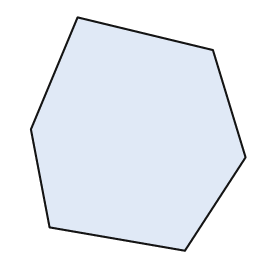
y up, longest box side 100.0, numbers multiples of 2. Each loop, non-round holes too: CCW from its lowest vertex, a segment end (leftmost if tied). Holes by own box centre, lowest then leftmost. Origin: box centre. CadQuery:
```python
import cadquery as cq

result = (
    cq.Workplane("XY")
    .moveTo(20.0, -50.0)
    .lineTo(46.0, -10.0)
    .lineTo(32.0, 36.0)
    .lineTo(-26.0, 50.0)
    .lineTo(-46.0, 2.0)
    .lineTo(-38.0, -40.0)
    .close()
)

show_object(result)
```